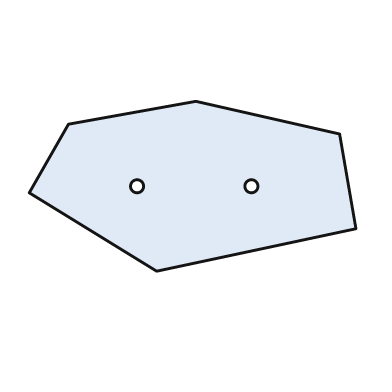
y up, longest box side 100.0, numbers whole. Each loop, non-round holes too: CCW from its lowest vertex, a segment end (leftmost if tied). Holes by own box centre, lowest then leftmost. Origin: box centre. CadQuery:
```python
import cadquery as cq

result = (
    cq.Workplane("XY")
    .moveTo(-11.0, -26.0)
    .lineTo(50.0, -13.0)
    .lineTo(45.0, 16.0)
    .lineTo(1.0, 26.0)
    .lineTo(-38.0, 19.0)
    .lineTo(-50.0, -2.0)
    .close()
    .moveTo(-17.0, 0.0)
    .circle(2.0)
    .moveTo(18.0, 0.0)
    .circle(2.0)
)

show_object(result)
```